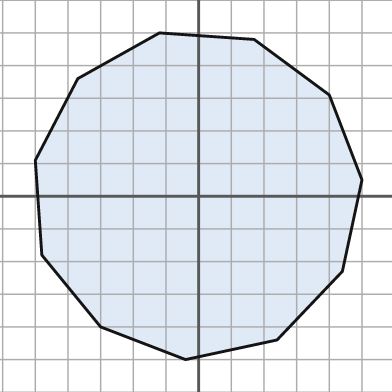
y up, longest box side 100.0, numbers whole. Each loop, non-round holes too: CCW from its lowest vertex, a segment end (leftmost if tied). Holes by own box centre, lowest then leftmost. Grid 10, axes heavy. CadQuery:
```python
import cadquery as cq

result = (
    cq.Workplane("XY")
    .moveTo(-4.0, -50.0)
    .lineTo(24.0, -44.0)
    .lineTo(44.0, -23.0)
    .lineTo(50.0, 5.0)
    .lineTo(40.0, 31.0)
    .lineTo(17.0, 48.0)
    .lineTo(-12.0, 50.0)
    .lineTo(-37.0, 36.0)
    .lineTo(-50.0, 11.0)
    .lineTo(-48.0, -18.0)
    .lineTo(-30.0, -40.0)
    .close()
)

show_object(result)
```